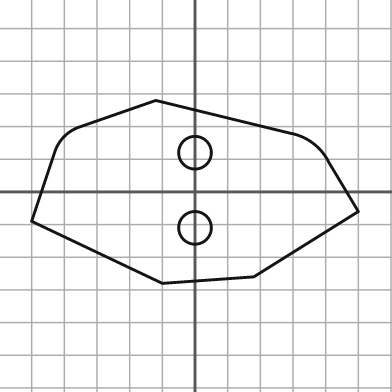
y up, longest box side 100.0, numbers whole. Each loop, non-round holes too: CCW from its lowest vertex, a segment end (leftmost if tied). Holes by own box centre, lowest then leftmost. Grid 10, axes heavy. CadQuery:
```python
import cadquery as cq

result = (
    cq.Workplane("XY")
    .moveTo(-10.0, -28.0)
    .lineTo(18.0, -26.0)
    .lineTo(50.0, -6.0)
    .lineTo(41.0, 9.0)
    .threePointArc((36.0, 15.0), (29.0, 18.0))
    .lineTo(-12.0, 28.0)
    .lineTo(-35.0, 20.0)
    .threePointArc((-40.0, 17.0), (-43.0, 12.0))
    .lineTo(-50.0, -9.0)
    .close()
    .moveTo(0.0, -11.0)
    .circle(5.0)
    .moveTo(0.0, 12.0)
    .circle(5.0)
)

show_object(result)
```